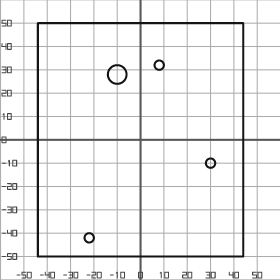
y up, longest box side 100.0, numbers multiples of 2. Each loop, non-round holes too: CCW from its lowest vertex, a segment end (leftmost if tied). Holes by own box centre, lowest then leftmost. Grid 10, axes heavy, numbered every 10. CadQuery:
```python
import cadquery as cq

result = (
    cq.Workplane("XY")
    .moveTo(-44.0, -50.0)
    .lineTo(44.0, -50.0)
    .lineTo(44.0, 50.0)
    .lineTo(-44.0, 50.0)
    .close()
    .moveTo(-22.0, -42.0)
    .circle(2.0)
    .moveTo(30.0, -10.0)
    .circle(2.0)
    .moveTo(-10.0, 28.0)
    .circle(4.0)
    .moveTo(8.0, 32.0)
    .circle(2.0)
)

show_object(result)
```